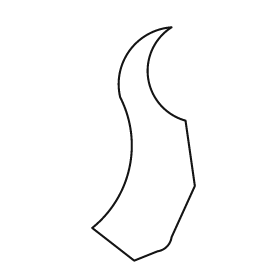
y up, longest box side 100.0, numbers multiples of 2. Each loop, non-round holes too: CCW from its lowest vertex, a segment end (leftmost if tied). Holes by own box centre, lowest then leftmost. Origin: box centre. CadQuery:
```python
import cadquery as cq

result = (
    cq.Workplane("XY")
    .moveTo(-4.0, -50.0)
    .lineTo(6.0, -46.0)
    .threePointArc((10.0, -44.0), (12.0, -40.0))
    .lineTo(22.0, -18.0)
    .lineTo(18.0, 10.0)
    .threePointArc((2.0, 28.0), (12.0, 50.0))
    .threePointArc((-6.0, 40.0), (-10.0, 20.0))
    .threePointArc((-6.0, -10.0), (-22.0, -36.0))
    .close()
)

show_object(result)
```